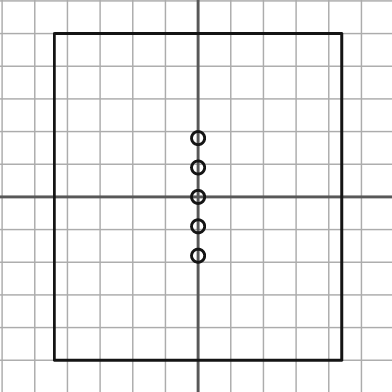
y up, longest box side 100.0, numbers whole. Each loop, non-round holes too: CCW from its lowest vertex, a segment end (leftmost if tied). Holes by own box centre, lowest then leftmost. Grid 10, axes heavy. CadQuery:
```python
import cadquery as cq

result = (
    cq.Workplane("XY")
    .moveTo(-44.0, -50.0)
    .lineTo(44.0, -50.0)
    .lineTo(44.0, 50.0)
    .lineTo(-44.0, 50.0)
    .close()
    .moveTo(0.0, -18.0)
    .circle(2.0)
    .moveTo(0.0, -9.0)
    .circle(2.0)
    .moveTo(0.0, 0.0)
    .circle(2.0)
    .moveTo(0.0, 9.0)
    .circle(2.0)
    .moveTo(0.0, 18.0)
    .circle(2.0)
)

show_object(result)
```